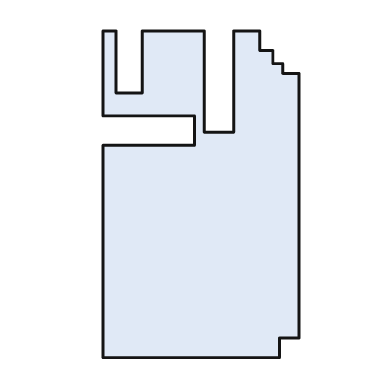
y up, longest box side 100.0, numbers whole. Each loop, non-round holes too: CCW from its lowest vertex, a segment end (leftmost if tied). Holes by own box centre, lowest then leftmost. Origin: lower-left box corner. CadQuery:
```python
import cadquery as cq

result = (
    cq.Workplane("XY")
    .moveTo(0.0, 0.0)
    .lineTo(54.0, 0.0)
    .lineTo(54.0, 6.0)
    .lineTo(60.0, 6.0)
    .lineTo(60.0, 87.0)
    .lineTo(55.0, 87.0)
    .lineTo(55.0, 90.0)
    .lineTo(52.0, 90.0)
    .lineTo(52.0, 94.0)
    .lineTo(48.0, 94.0)
    .lineTo(48.0, 100.0)
    .lineTo(40.0, 100.0)
    .lineTo(40.0, 69.0)
    .lineTo(31.0, 69.0)
    .lineTo(31.0, 100.0)
    .lineTo(12.0, 100.0)
    .lineTo(12.0, 81.0)
    .lineTo(4.0, 81.0)
    .lineTo(4.0, 100.0)
    .lineTo(0.0, 100.0)
    .lineTo(0.0, 74.0)
    .lineTo(28.0, 74.0)
    .lineTo(28.0, 65.0)
    .lineTo(0.0, 65.0)
    .close()
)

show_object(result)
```